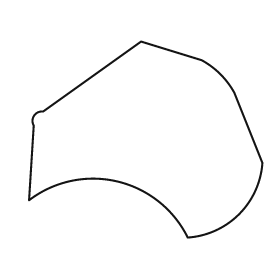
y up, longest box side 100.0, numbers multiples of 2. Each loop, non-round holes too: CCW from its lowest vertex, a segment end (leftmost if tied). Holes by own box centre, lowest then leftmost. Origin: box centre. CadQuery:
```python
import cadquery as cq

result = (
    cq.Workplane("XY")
    .moveTo(18.0, -42.0)
    .threePointArc((40.0, -32.0), (50.0, -10.0))
    .lineTo(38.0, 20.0)
    .threePointArc((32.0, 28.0), (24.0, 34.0))
    .lineTo(-2.0, 42.0)
    .lineTo(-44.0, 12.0)
    .threePointArc((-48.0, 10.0), (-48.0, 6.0))
    .lineTo(-50.0, -26.0)
    .threePointArc((-12.0, -18.0), (18.0, -42.0))
    .close()
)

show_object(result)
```